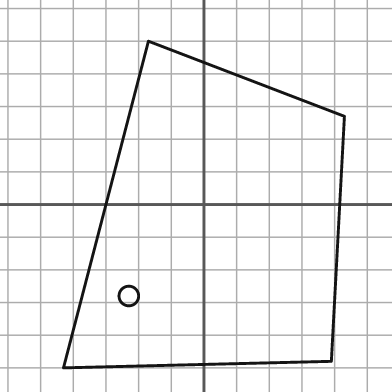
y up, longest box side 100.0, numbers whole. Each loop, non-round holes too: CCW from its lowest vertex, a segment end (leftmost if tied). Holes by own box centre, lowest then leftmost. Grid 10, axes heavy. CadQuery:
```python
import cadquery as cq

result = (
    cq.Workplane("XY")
    .moveTo(-43.0, -50.0)
    .lineTo(39.0, -48.0)
    .lineTo(43.0, 27.0)
    .lineTo(-17.0, 50.0)
    .close()
    .moveTo(-23.0, -28.0)
    .circle(3.0)
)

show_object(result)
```